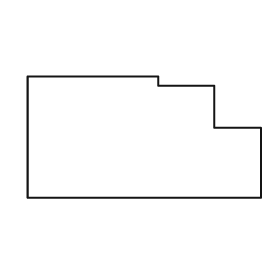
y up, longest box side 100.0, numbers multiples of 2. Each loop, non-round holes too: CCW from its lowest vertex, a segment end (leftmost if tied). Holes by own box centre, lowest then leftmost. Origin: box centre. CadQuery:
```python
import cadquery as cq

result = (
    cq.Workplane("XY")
    .moveTo(-50.0, -26.0)
    .lineTo(50.0, -26.0)
    .lineTo(50.0, 4.0)
    .lineTo(30.0, 4.0)
    .lineTo(30.0, 22.0)
    .lineTo(6.0, 22.0)
    .lineTo(6.0, 26.0)
    .lineTo(-50.0, 26.0)
    .close()
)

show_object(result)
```